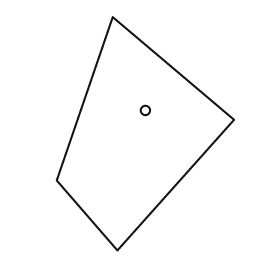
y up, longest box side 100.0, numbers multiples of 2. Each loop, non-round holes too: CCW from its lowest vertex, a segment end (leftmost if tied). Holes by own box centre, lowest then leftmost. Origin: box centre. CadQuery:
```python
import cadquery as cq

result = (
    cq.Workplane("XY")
    .moveTo(-12.0, -50.0)
    .lineTo(38.0, 6.0)
    .lineTo(-14.0, 50.0)
    .lineTo(-38.0, -20.0)
    .close()
    .moveTo(0.0, 10.0)
    .circle(2.0)
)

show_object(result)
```